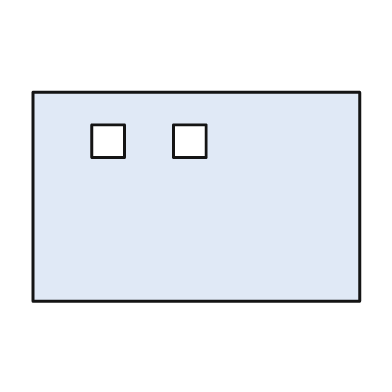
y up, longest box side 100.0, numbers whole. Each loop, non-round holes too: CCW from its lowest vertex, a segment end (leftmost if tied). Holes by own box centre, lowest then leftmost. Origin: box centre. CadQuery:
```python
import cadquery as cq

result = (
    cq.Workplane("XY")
    .moveTo(-50.0, -32.0)
    .lineTo(50.0, -32.0)
    .lineTo(50.0, 32.0)
    .lineTo(-50.0, 32.0)
    .close()
    .moveTo(-32.0, 12.0)
    .lineTo(-22.0, 12.0)
    .lineTo(-22.0, 22.0)
    .lineTo(-32.0, 22.0)
    .close()
    .moveTo(-7.0, 12.0)
    .lineTo(3.0, 12.0)
    .lineTo(3.0, 22.0)
    .lineTo(-7.0, 22.0)
    .close()
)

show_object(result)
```